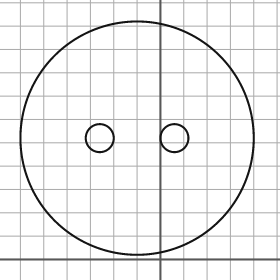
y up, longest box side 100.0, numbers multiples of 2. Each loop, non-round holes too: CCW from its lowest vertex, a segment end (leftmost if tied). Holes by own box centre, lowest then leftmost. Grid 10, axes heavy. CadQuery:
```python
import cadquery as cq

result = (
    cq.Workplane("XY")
    .moveTo(-10.0, 52.0)
    .circle(50.0)
    .moveTo(-26.0, 52.0)
    .circle(6.0)
    .moveTo(6.0, 52.0)
    .circle(6.0)
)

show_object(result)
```